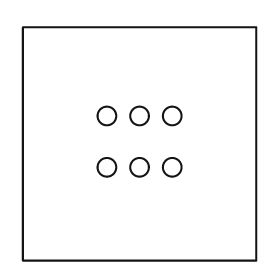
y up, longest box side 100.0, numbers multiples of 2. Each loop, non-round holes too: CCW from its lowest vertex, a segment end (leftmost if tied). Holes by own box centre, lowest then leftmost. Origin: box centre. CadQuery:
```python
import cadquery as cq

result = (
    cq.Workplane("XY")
    .moveTo(-50.0, -50.0)
    .lineTo(50.0, -50.0)
    .lineTo(50.0, 50.0)
    .lineTo(-50.0, 50.0)
    .close()
    .moveTo(-14.0, -10.0)
    .circle(4.0)
    .moveTo(0.0, -10.0)
    .circle(4.0)
    .moveTo(14.0, -10.0)
    .circle(4.0)
    .moveTo(-14.0, 12.0)
    .circle(4.0)
    .moveTo(0.0, 12.0)
    .circle(4.0)
    .moveTo(14.0, 12.0)
    .circle(4.0)
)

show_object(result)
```